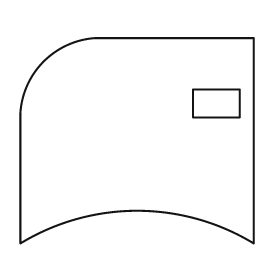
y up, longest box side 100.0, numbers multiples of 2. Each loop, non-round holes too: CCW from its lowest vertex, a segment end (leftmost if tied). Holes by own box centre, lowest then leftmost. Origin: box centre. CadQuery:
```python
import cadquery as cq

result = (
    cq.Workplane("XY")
    .moveTo(-50.0, -44.0)
    .threePointArc((0.0, -30.0), (50.0, -44.0))
    .lineTo(50.0, 44.0)
    .lineTo(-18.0, 44.0)
    .threePointArc((-40.0, 34.0), (-50.0, 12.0))
    .close()
    .moveTo(24.0, 10.0)
    .lineTo(44.0, 10.0)
    .lineTo(44.0, 22.0)
    .lineTo(24.0, 22.0)
    .close()
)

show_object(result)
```